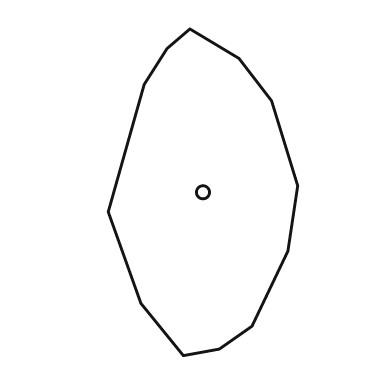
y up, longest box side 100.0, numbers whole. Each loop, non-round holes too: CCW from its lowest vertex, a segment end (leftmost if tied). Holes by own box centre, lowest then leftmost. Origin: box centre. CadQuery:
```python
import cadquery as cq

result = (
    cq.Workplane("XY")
    .moveTo(-6.0, -50.0)
    .lineTo(5.0, -48.0)
    .lineTo(15.0, -41.0)
    .lineTo(26.0, -18.0)
    .lineTo(29.0, 2.0)
    .lineTo(21.0, 28.0)
    .lineTo(11.0, 41.0)
    .lineTo(-4.0, 50.0)
    .lineTo(-11.0, 44.0)
    .lineTo(-18.0, 33.0)
    .lineTo(-29.0, -6.0)
    .lineTo(-19.0, -34.0)
    .close()
    .moveTo(0.0, 0.0)
    .circle(2.0)
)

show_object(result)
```